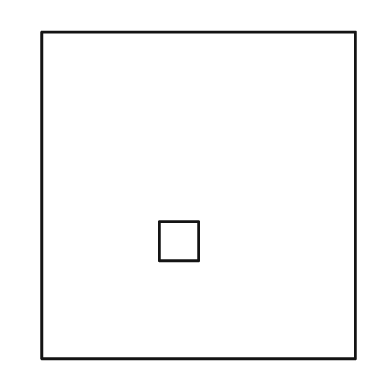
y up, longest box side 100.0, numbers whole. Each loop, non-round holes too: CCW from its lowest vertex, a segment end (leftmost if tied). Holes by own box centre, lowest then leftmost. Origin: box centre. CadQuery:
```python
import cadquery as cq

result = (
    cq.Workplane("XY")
    .moveTo(-48.0, -50.0)
    .lineTo(48.0, -50.0)
    .lineTo(48.0, 50.0)
    .lineTo(-48.0, 50.0)
    .close()
    .moveTo(-12.0, -20.0)
    .lineTo(0.0, -20.0)
    .lineTo(0.0, -8.0)
    .lineTo(-12.0, -8.0)
    .close()
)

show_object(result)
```